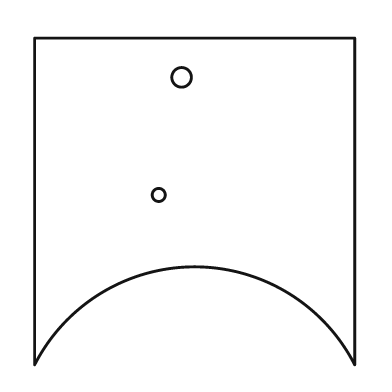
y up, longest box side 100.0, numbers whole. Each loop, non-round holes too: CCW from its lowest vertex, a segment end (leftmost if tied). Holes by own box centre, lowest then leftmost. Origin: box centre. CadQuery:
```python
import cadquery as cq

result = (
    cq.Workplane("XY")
    .moveTo(-49.0, -50.0)
    .threePointArc((0.0, -20.0), (49.0, -50.0))
    .lineTo(49.0, 50.0)
    .lineTo(-49.0, 50.0)
    .close()
    .moveTo(-11.0, 2.0)
    .circle(2.0)
    .moveTo(-4.0, 38.0)
    .circle(3.0)
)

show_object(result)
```